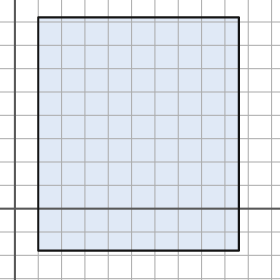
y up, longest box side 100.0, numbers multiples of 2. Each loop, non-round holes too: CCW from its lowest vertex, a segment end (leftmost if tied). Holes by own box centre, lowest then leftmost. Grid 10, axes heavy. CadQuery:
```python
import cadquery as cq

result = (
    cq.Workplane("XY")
    .moveTo(10.0, -18.0)
    .lineTo(96.0, -18.0)
    .lineTo(96.0, 82.0)
    .lineTo(10.0, 82.0)
    .close()
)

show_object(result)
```